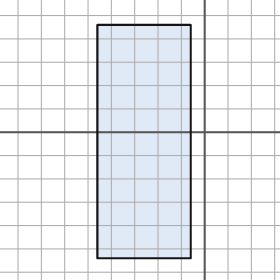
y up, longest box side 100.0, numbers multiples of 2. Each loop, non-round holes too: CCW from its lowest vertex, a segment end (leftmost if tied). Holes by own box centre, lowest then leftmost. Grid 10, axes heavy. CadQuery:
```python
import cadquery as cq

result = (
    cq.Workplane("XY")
    .moveTo(-46.0, -54.0)
    .lineTo(-6.0, -54.0)
    .lineTo(-6.0, 46.0)
    .lineTo(-46.0, 46.0)
    .close()
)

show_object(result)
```